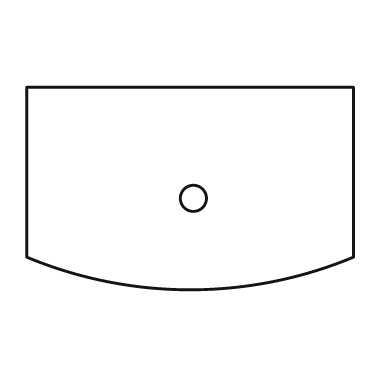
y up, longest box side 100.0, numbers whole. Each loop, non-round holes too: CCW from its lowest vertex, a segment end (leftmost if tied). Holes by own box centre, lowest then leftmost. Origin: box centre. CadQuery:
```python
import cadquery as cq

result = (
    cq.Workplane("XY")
    .moveTo(-50.0, -21.0)
    .threePointArc((0.0, -31.0), (50.0, -21.0))
    .lineTo(50.0, 31.0)
    .lineTo(-50.0, 31.0)
    .close()
    .moveTo(1.0, -3.0)
    .circle(4.0)
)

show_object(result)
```